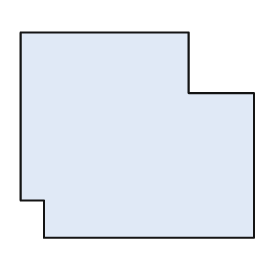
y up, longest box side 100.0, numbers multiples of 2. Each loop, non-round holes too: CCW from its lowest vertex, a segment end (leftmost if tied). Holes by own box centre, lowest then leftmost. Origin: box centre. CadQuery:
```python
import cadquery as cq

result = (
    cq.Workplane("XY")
    .moveTo(-40.0, -44.0)
    .lineTo(50.0, -44.0)
    .lineTo(50.0, 18.0)
    .lineTo(22.0, 18.0)
    .lineTo(22.0, 44.0)
    .lineTo(-50.0, 44.0)
    .lineTo(-50.0, -28.0)
    .lineTo(-40.0, -28.0)
    .close()
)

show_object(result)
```